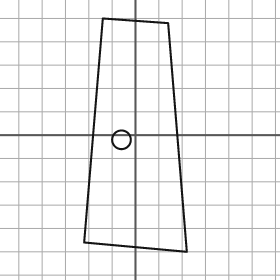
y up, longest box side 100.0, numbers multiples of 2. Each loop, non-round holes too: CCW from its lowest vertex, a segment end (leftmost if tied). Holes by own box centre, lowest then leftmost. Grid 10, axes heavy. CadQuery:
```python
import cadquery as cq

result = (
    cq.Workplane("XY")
    .moveTo(22.0, -50.0)
    .lineTo(14.0, 48.0)
    .lineTo(-14.0, 50.0)
    .lineTo(-22.0, -46.0)
    .close()
    .moveTo(-6.0, -2.0)
    .circle(4.0)
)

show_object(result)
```